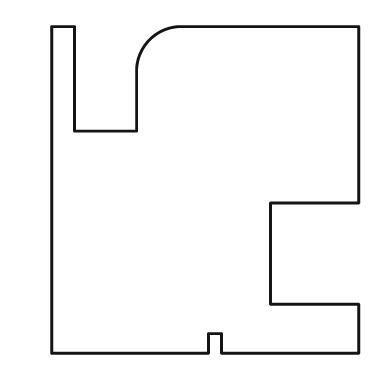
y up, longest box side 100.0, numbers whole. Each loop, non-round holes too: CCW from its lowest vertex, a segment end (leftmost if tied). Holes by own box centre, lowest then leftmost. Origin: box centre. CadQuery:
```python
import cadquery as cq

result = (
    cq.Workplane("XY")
    .moveTo(-47.0, -50.0)
    .lineTo(1.0, -50.0)
    .lineTo(1.0, -44.0)
    .lineTo(5.0, -44.0)
    .lineTo(5.0, -50.0)
    .lineTo(47.0, -50.0)
    .lineTo(47.0, -35.0)
    .lineTo(20.0, -35.0)
    .lineTo(20.0, -4.0)
    .lineTo(47.0, -4.0)
    .lineTo(47.0, 50.0)
    .lineTo(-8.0, 50.0)
    .threePointArc((-17.0, 46.0), (-21.0, 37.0))
    .lineTo(-21.0, 18.0)
    .lineTo(-40.0, 18.0)
    .lineTo(-40.0, 50.0)
    .lineTo(-47.0, 50.0)
    .close()
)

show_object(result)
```